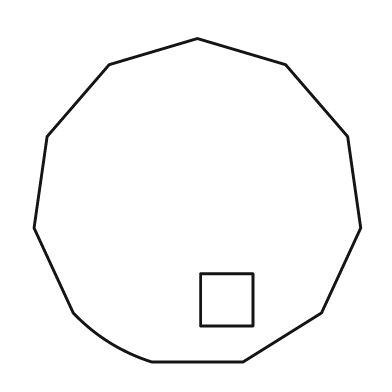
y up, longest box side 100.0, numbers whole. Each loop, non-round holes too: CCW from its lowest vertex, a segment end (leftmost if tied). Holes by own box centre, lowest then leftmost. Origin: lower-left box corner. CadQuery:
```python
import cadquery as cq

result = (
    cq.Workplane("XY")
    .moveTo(36.0, 0.0)
    .lineTo(64.0, 0.0)
    .lineTo(88.0, 15.0)
    .lineTo(100.0, 41.0)
    .lineTo(96.0, 69.0)
    .lineTo(77.0, 91.0)
    .lineTo(50.0, 99.0)
    .lineTo(23.0, 91.0)
    .lineTo(4.0, 69.0)
    .lineTo(0.0, 41.0)
    .lineTo(12.0, 15.0)
    .threePointArc((23.0, 6.0), (36.0, 0.0))
    .close()
    .moveTo(51.0, 11.0)
    .lineTo(67.0, 11.0)
    .lineTo(67.0, 27.0)
    .lineTo(51.0, 27.0)
    .close()
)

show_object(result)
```